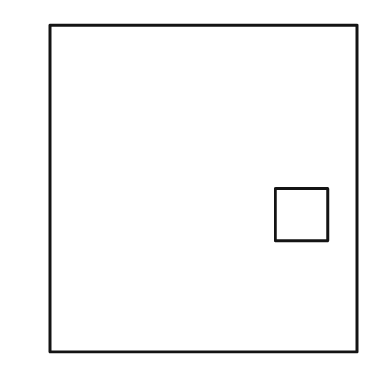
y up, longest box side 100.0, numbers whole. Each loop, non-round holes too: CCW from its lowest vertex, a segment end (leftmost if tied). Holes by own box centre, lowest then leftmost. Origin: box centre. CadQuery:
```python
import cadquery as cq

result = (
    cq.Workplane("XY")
    .moveTo(-47.0, -50.0)
    .lineTo(47.0, -50.0)
    .lineTo(47.0, 50.0)
    .lineTo(-47.0, 50.0)
    .close()
    .moveTo(22.0, -16.0)
    .lineTo(38.0, -16.0)
    .lineTo(38.0, 0.0)
    .lineTo(22.0, 0.0)
    .close()
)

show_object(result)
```